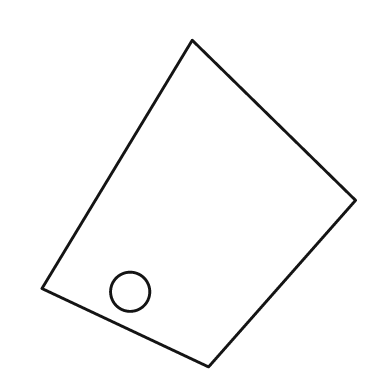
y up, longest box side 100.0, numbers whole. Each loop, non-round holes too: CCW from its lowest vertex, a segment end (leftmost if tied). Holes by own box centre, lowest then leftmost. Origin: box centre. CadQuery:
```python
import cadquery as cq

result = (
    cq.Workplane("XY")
    .moveTo(3.0, -50.0)
    .lineTo(48.0, 1.0)
    .lineTo(-2.0, 50.0)
    .lineTo(-48.0, -26.0)
    .close()
    .moveTo(-21.0, -27.0)
    .circle(6.0)
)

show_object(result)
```